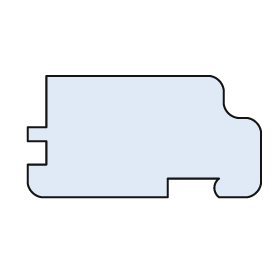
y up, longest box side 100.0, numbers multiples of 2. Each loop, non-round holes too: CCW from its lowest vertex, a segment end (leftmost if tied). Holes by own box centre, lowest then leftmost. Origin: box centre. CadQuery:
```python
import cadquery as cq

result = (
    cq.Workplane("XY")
    .moveTo(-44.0, -26.0)
    .lineTo(10.0, -26.0)
    .lineTo(10.0, -18.0)
    .lineTo(32.0, -18.0)
    .threePointArc((30.0, -22.0), (32.0, -26.0))
    .lineTo(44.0, -26.0)
    .threePointArc((48.0, -24.0), (50.0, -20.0))
    .lineTo(50.0, 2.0)
    .threePointArc((48.0, 6.0), (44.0, 8.0))
    .lineTo(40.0, 8.0)
    .threePointArc((36.0, 10.0), (34.0, 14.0))
    .lineTo(34.0, 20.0)
    .threePointArc((32.0, 24.0), (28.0, 26.0))
    .lineTo(-42.0, 26.0)
    .lineTo(-42.0, 4.0)
    .lineTo(-50.0, 4.0)
    .lineTo(-50.0, -2.0)
    .lineTo(-42.0, -2.0)
    .lineTo(-42.0, -12.0)
    .lineTo(-50.0, -12.0)
    .lineTo(-50.0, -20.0)
    .threePointArc((-48.0, -24.0), (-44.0, -26.0))
    .close()
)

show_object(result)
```